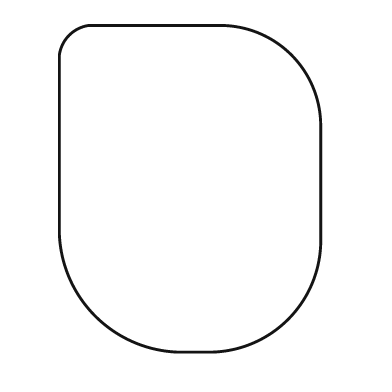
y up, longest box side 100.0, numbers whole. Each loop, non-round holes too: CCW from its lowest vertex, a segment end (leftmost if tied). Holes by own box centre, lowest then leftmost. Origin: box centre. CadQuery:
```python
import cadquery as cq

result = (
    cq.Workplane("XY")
    .moveTo(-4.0, -50.0)
    .lineTo(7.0, -50.0)
    .threePointArc((30.0, -40.0), (40.0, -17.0))
    .lineTo(40.0, 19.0)
    .threePointArc((31.0, 41.0), (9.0, 50.0))
    .lineTo(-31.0, 50.0)
    .threePointArc((-37.0, 47.0), (-40.0, 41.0))
    .lineTo(-40.0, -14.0)
    .threePointArc((-29.0, -39.0), (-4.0, -50.0))
    .close()
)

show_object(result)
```